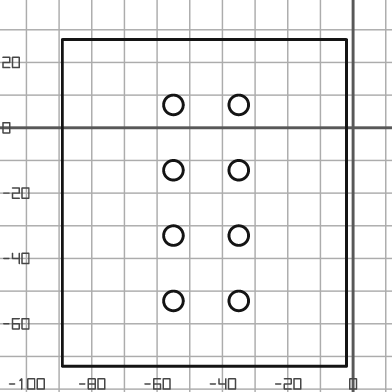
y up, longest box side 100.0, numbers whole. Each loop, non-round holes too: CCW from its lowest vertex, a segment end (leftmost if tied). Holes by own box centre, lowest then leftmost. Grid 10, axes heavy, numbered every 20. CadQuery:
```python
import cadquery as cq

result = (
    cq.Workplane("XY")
    .moveTo(-89.0, -73.0)
    .lineTo(-2.0, -73.0)
    .lineTo(-2.0, 27.0)
    .lineTo(-89.0, 27.0)
    .close()
    .moveTo(-55.0, -53.0)
    .circle(3.0)
    .moveTo(-35.0, -53.0)
    .circle(3.0)
    .moveTo(-55.0, -33.0)
    .circle(3.0)
    .moveTo(-35.0, -33.0)
    .circle(3.0)
    .moveTo(-55.0, -13.0)
    .circle(3.0)
    .moveTo(-35.0, -13.0)
    .circle(3.0)
    .moveTo(-55.0, 7.0)
    .circle(3.0)
    .moveTo(-35.0, 7.0)
    .circle(3.0)
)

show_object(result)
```